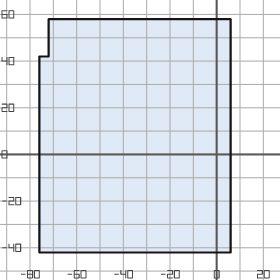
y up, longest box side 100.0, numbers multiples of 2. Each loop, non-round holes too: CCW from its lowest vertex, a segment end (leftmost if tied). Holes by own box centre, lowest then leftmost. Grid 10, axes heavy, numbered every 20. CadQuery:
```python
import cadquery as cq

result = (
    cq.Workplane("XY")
    .moveTo(-76.0, -42.0)
    .lineTo(6.0, -42.0)
    .lineTo(6.0, 58.0)
    .lineTo(-72.0, 58.0)
    .lineTo(-72.0, 42.0)
    .lineTo(-76.0, 42.0)
    .close()
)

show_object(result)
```